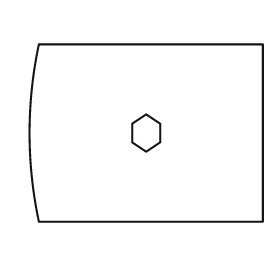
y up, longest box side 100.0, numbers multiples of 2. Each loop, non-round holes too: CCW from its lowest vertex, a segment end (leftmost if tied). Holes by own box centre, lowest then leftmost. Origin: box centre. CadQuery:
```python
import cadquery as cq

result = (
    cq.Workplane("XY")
    .moveTo(-46.0, -38.0)
    .lineTo(50.0, -38.0)
    .lineTo(50.0, 38.0)
    .lineTo(-46.0, 38.0)
    .threePointArc((-50.0, 0.0), (-46.0, -38.0))
    .close()
    .moveTo(0.0, -8.0)
    .lineTo(6.0, -4.0)
    .lineTo(6.0, 4.0)
    .lineTo(0.0, 8.0)
    .lineTo(-6.0, 4.0)
    .lineTo(-6.0, -4.0)
    .close()
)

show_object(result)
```